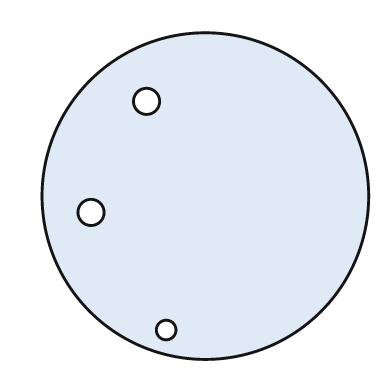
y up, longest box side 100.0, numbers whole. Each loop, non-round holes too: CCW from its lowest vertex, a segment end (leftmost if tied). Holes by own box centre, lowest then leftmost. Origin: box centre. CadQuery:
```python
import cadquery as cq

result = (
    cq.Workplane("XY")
    .moveTo(0.0, 0.0)
    .circle(50.0)
    .moveTo(-12.0, -41.0)
    .circle(3.0)
    .moveTo(-35.0, -5.0)
    .circle(4.0)
    .moveTo(-18.0, 29.0)
    .circle(4.0)
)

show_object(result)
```